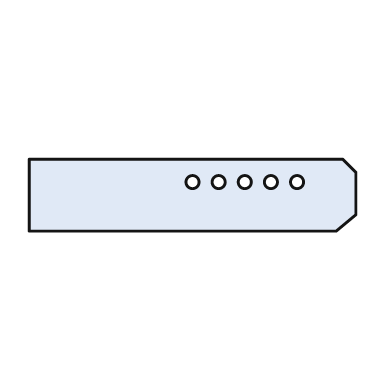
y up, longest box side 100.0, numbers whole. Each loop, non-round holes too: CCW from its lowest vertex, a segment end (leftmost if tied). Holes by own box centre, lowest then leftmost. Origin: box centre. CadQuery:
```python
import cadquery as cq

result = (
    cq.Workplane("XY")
    .moveTo(-50.0, -11.0)
    .lineTo(44.0, -11.0)
    .lineTo(50.0, -6.0)
    .lineTo(50.0, 7.0)
    .lineTo(46.0, 11.0)
    .lineTo(-50.0, 11.0)
    .close()
    .moveTo(0.0, 4.0)
    .circle(2.0)
    .moveTo(8.0, 4.0)
    .circle(2.0)
    .moveTo(16.0, 4.0)
    .circle(2.0)
    .moveTo(24.0, 4.0)
    .circle(2.0)
    .moveTo(32.0, 4.0)
    .circle(2.0)
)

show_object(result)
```